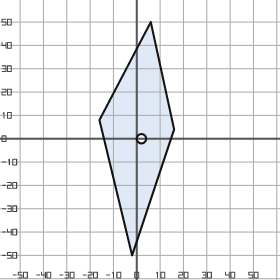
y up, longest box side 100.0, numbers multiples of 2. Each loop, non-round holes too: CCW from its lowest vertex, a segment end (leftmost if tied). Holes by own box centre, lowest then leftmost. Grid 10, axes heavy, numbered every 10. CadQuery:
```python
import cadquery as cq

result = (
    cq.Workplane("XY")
    .moveTo(-2.0, -50.0)
    .lineTo(16.0, 4.0)
    .lineTo(6.0, 50.0)
    .lineTo(-16.0, 8.0)
    .close()
    .moveTo(2.0, 0.0)
    .circle(2.0)
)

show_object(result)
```